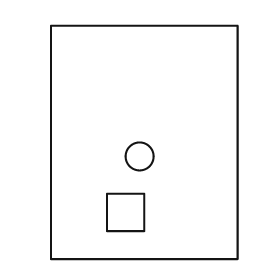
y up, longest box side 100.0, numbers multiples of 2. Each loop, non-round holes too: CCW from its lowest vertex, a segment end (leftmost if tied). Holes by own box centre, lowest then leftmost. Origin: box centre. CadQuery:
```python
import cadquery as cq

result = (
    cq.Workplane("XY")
    .moveTo(-40.0, -50.0)
    .lineTo(40.0, -50.0)
    .lineTo(40.0, 50.0)
    .lineTo(-40.0, 50.0)
    .close()
    .moveTo(-16.0, -38.0)
    .lineTo(0.0, -38.0)
    .lineTo(0.0, -22.0)
    .lineTo(-16.0, -22.0)
    .close()
    .moveTo(-2.0, -6.0)
    .circle(6.0)
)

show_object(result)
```